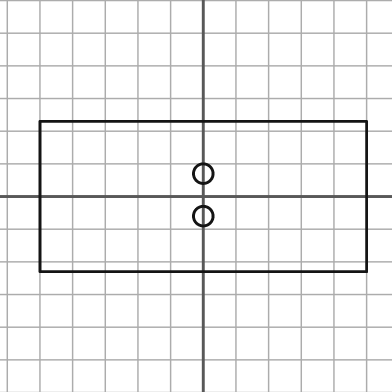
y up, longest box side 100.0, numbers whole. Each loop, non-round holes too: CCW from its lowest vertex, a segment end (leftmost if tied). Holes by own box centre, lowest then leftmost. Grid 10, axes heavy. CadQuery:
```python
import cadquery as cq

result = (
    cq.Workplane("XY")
    .moveTo(-50.0, -23.0)
    .lineTo(50.0, -23.0)
    .lineTo(50.0, 23.0)
    .lineTo(-50.0, 23.0)
    .close()
    .moveTo(0.0, -6.0)
    .circle(3.0)
    .moveTo(0.0, 7.0)
    .circle(3.0)
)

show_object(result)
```